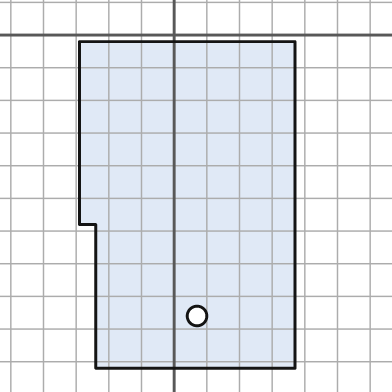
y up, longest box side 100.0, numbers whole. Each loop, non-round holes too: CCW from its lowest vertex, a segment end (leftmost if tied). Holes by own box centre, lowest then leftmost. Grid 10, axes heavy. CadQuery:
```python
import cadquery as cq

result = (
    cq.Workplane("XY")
    .moveTo(-24.0, -102.0)
    .lineTo(37.0, -102.0)
    .lineTo(37.0, -2.0)
    .lineTo(-29.0, -2.0)
    .lineTo(-29.0, -58.0)
    .lineTo(-24.0, -58.0)
    .close()
    .moveTo(7.0, -86.0)
    .circle(3.0)
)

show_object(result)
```